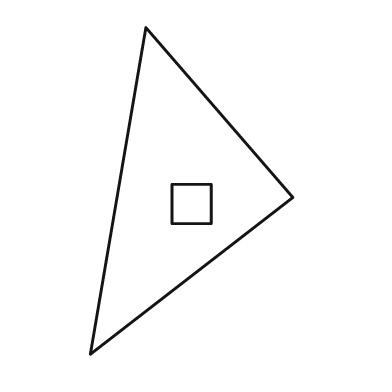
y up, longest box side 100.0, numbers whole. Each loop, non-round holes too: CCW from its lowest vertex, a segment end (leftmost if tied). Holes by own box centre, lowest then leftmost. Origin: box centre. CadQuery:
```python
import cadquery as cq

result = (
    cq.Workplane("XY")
    .moveTo(-31.0, -50.0)
    .lineTo(31.0, -2.0)
    .lineTo(-14.0, 50.0)
    .close()
    .moveTo(-6.0, -10.0)
    .lineTo(6.0, -10.0)
    .lineTo(6.0, 2.0)
    .lineTo(-6.0, 2.0)
    .close()
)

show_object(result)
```